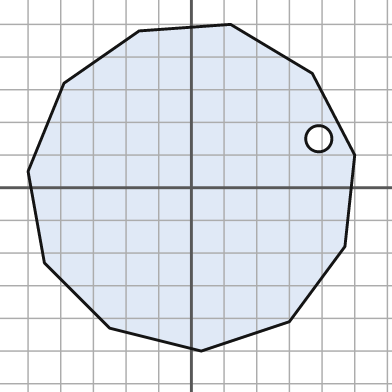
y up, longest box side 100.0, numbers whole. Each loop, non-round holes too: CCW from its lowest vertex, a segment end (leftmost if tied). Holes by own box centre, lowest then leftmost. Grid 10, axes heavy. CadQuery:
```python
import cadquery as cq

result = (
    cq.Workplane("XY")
    .moveTo(3.0, -50.0)
    .lineTo(30.0, -41.0)
    .lineTo(47.0, -18.0)
    .lineTo(50.0, 10.0)
    .lineTo(37.0, 35.0)
    .lineTo(12.0, 50.0)
    .lineTo(-16.0, 48.0)
    .lineTo(-39.0, 32.0)
    .lineTo(-50.0, 5.0)
    .lineTo(-45.0, -23.0)
    .lineTo(-25.0, -43.0)
    .close()
    .moveTo(39.0, 15.0)
    .circle(4.0)
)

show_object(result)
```